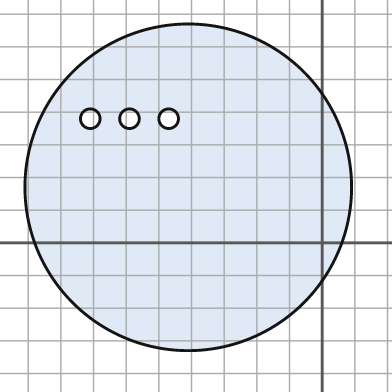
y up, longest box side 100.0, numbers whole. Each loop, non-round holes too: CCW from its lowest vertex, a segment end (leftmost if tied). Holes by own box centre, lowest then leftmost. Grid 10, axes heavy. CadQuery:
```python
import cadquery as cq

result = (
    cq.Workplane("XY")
    .moveTo(-41.0, 17.0)
    .circle(50.0)
    .moveTo(-71.0, 38.0)
    .circle(3.0)
    .moveTo(-59.0, 38.0)
    .circle(3.0)
    .moveTo(-47.0, 38.0)
    .circle(3.0)
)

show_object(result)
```